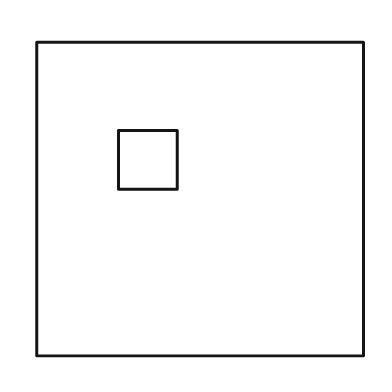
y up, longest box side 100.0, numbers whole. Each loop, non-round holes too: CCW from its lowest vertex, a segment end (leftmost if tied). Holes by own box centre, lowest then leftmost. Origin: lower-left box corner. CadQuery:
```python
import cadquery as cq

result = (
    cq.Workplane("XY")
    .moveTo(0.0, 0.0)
    .lineTo(100.0, 0.0)
    .lineTo(100.0, 96.0)
    .lineTo(0.0, 96.0)
    .close()
    .moveTo(25.0, 51.0)
    .lineTo(43.0, 51.0)
    .lineTo(43.0, 69.0)
    .lineTo(25.0, 69.0)
    .close()
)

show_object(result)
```